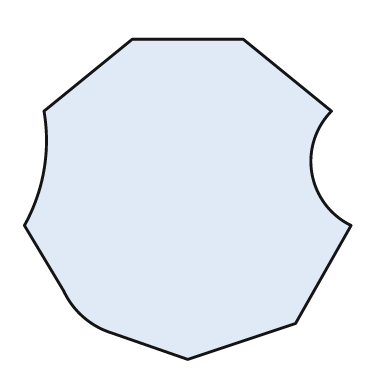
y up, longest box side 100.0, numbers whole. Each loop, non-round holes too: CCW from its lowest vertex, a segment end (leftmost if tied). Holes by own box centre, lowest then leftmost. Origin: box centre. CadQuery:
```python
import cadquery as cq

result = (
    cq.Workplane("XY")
    .moveTo(0.0, -49.0)
    .lineTo(33.0, -38.0)
    .lineTo(50.0, -8.0)
    .threePointArc((38.0, 8.0), (44.0, 27.0))
    .lineTo(17.0, 49.0)
    .lineTo(-17.0, 49.0)
    .lineTo(-44.0, 27.0)
    .threePointArc((-44.0, 9.0), (-50.0, -8.0))
    .lineTo(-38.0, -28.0)
    .threePointArc((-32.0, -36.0), (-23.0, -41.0))
    .close()
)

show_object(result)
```